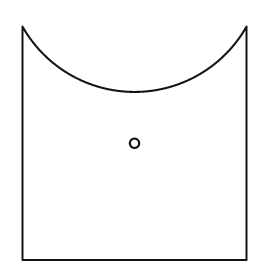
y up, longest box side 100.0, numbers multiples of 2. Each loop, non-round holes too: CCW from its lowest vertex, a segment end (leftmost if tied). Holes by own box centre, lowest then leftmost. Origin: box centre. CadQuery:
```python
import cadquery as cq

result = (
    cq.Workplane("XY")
    .moveTo(-48.0, -50.0)
    .lineTo(48.0, -50.0)
    .lineTo(48.0, 50.0)
    .threePointArc((0.0, 22.0), (-48.0, 50.0))
    .close()
    .moveTo(0.0, 0.0)
    .circle(2.0)
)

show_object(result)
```